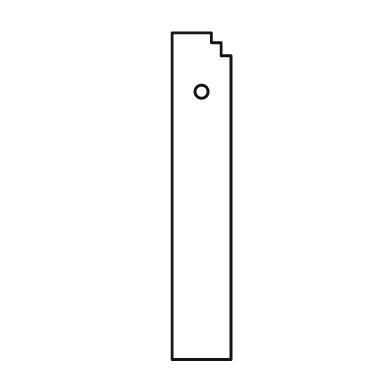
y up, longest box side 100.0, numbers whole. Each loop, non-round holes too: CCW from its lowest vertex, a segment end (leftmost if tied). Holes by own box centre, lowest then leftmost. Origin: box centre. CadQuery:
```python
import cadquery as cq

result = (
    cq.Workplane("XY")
    .moveTo(-9.0, -50.0)
    .lineTo(9.0, -50.0)
    .lineTo(9.0, 43.0)
    .lineTo(6.0, 43.0)
    .lineTo(6.0, 47.0)
    .lineTo(3.0, 47.0)
    .lineTo(3.0, 50.0)
    .lineTo(-9.0, 50.0)
    .close()
    .moveTo(0.0, 32.0)
    .circle(2.0)
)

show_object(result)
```